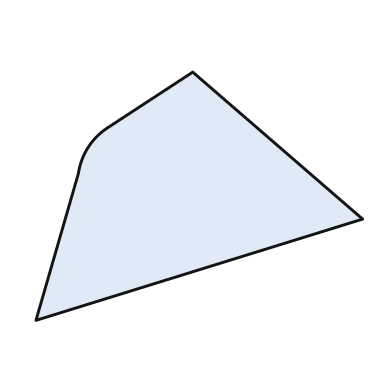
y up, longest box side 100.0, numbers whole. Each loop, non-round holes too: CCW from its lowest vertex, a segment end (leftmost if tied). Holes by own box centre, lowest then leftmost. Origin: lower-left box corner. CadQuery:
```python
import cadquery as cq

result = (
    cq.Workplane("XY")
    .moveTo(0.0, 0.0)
    .lineTo(100.0, 31.0)
    .lineTo(48.0, 76.0)
    .lineTo(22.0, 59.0)
    .threePointArc((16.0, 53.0), (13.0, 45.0))
    .close()
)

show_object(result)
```